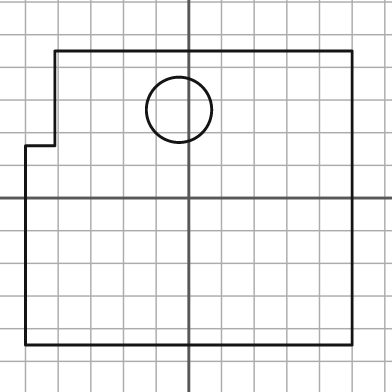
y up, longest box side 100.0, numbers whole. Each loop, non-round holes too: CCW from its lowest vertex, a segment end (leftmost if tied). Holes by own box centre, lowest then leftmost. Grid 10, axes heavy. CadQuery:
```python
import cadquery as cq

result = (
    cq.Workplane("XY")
    .moveTo(-50.0, -45.0)
    .lineTo(50.0, -45.0)
    .lineTo(50.0, 45.0)
    .lineTo(-41.0, 45.0)
    .lineTo(-41.0, 16.0)
    .lineTo(-50.0, 16.0)
    .close()
    .moveTo(-3.0, 27.0)
    .circle(10.0)
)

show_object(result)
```